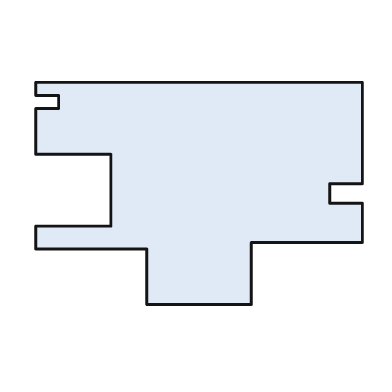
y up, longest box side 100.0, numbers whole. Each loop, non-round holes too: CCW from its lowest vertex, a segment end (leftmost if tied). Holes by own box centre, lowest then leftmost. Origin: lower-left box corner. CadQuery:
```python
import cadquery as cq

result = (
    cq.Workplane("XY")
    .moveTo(34.0, 0.0)
    .lineTo(66.0, 0.0)
    .lineTo(66.0, 19.0)
    .lineTo(100.0, 19.0)
    .lineTo(100.0, 31.0)
    .lineTo(90.0, 31.0)
    .lineTo(90.0, 37.0)
    .lineTo(100.0, 37.0)
    .lineTo(100.0, 68.0)
    .lineTo(0.0, 68.0)
    .lineTo(0.0, 64.0)
    .lineTo(7.0, 64.0)
    .lineTo(7.0, 60.0)
    .lineTo(0.0, 60.0)
    .lineTo(0.0, 46.0)
    .lineTo(23.0, 46.0)
    .lineTo(23.0, 24.0)
    .lineTo(0.0, 24.0)
    .lineTo(0.0, 17.0)
    .lineTo(34.0, 17.0)
    .close()
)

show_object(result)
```